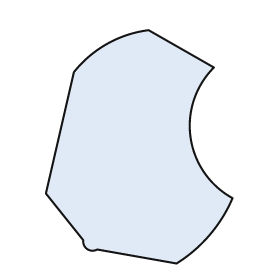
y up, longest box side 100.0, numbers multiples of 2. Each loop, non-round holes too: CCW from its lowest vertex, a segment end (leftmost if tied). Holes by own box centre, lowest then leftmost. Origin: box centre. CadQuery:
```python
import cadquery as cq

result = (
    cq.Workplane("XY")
    .moveTo(16.0, -50.0)
    .threePointArc((30.0, -38.0), (40.0, -22.0))
    .threePointArc((22.0, 4.0), (32.0, 34.0))
    .lineTo(4.0, 50.0)
    .threePointArc((-14.0, 44.0), (-28.0, 32.0))
    .lineTo(-40.0, -20.0)
    .lineTo(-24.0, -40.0)
    .threePointArc((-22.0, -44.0), (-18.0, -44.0))
    .close()
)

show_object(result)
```